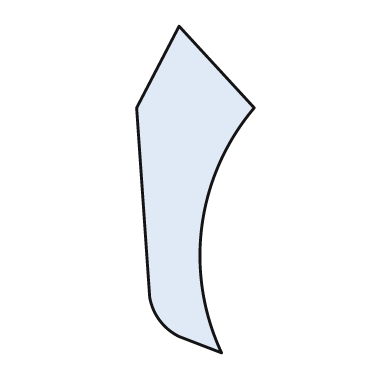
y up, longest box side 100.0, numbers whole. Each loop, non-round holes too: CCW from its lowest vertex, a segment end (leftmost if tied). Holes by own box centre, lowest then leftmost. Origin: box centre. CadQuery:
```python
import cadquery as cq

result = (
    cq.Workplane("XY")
    .moveTo(8.0, -50.0)
    .threePointArc((2.0, -11.0), (18.0, 25.0))
    .lineTo(-5.0, 50.0)
    .lineTo(-18.0, 25.0)
    .lineTo(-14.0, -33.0)
    .threePointArc((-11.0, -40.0), (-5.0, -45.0))
    .close()
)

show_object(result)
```